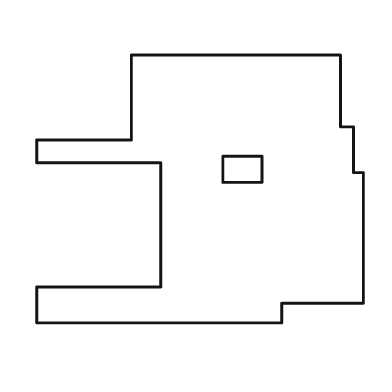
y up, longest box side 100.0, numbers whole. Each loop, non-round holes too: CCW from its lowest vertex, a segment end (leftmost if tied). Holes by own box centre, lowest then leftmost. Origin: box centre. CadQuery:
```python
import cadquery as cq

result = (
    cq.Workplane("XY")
    .moveTo(-50.0, -41.0)
    .lineTo(25.0, -41.0)
    .lineTo(25.0, -35.0)
    .lineTo(50.0, -35.0)
    .lineTo(50.0, 5.0)
    .lineTo(47.0, 5.0)
    .lineTo(47.0, 19.0)
    .lineTo(43.0, 19.0)
    .lineTo(43.0, 41.0)
    .lineTo(-21.0, 41.0)
    .lineTo(-21.0, 15.0)
    .lineTo(-50.0, 15.0)
    .lineTo(-50.0, 8.0)
    .lineTo(-12.0, 8.0)
    .lineTo(-12.0, -30.0)
    .lineTo(-50.0, -30.0)
    .close()
    .moveTo(7.0, 2.0)
    .lineTo(19.0, 2.0)
    .lineTo(19.0, 10.0)
    .lineTo(7.0, 10.0)
    .close()
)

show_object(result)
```